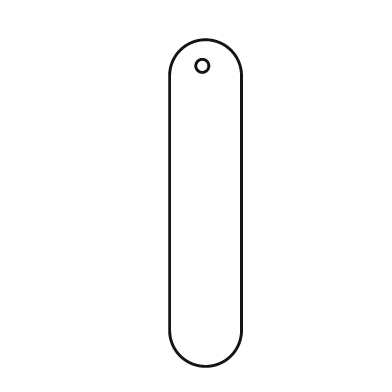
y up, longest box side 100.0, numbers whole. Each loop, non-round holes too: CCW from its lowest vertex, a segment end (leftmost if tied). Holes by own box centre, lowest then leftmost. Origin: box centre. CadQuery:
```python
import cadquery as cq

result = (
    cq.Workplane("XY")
    .moveTo(-11.0, -39.0)
    .threePointArc((0.0, -50.0), (11.0, -39.0))
    .lineTo(11.0, 39.0)
    .threePointArc((0.0, 50.0), (-11.0, 39.0))
    .close()
    .moveTo(-1.0, 42.0)
    .circle(2.0)
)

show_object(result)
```